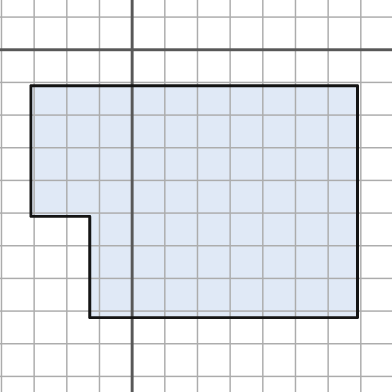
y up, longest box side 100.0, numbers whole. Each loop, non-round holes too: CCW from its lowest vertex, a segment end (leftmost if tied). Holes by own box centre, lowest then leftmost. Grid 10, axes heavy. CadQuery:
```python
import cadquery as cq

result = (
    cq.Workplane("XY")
    .moveTo(-13.0, -82.0)
    .lineTo(69.0, -82.0)
    .lineTo(69.0, -11.0)
    .lineTo(-31.0, -11.0)
    .lineTo(-31.0, -51.0)
    .lineTo(-13.0, -51.0)
    .close()
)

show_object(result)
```